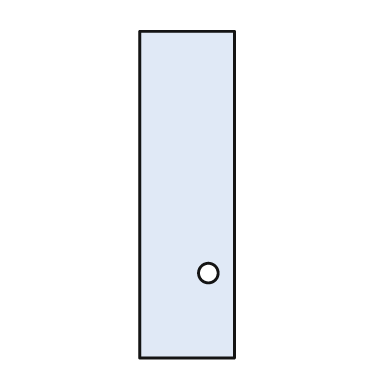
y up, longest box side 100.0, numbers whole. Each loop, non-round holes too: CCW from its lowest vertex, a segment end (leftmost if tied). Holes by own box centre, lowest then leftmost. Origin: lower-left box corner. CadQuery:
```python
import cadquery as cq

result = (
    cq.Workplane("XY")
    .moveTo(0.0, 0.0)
    .lineTo(29.0, 0.0)
    .lineTo(29.0, 100.0)
    .lineTo(0.0, 100.0)
    .close()
    .moveTo(21.0, 26.0)
    .circle(3.0)
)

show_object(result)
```